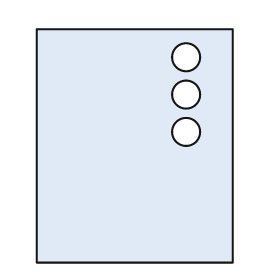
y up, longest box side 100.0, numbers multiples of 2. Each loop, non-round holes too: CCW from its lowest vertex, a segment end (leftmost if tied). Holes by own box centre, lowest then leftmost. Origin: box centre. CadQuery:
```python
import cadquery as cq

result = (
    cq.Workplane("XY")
    .moveTo(-42.0, -50.0)
    .lineTo(42.0, -50.0)
    .lineTo(42.0, 50.0)
    .lineTo(-42.0, 50.0)
    .close()
    .moveTo(22.0, 6.0)
    .circle(6.0)
    .moveTo(22.0, 22.0)
    .circle(6.0)
    .moveTo(22.0, 38.0)
    .circle(6.0)
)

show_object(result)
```